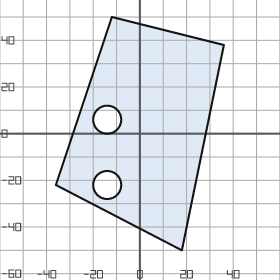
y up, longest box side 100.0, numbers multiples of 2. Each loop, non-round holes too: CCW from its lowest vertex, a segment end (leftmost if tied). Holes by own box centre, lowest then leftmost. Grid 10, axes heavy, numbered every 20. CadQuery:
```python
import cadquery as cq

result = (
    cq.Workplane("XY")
    .moveTo(18.0, -50.0)
    .lineTo(36.0, 38.0)
    .lineTo(-12.0, 50.0)
    .lineTo(-36.0, -22.0)
    .close()
    .moveTo(-14.0, -22.0)
    .circle(6.0)
    .moveTo(-14.0, 6.0)
    .circle(6.0)
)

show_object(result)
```